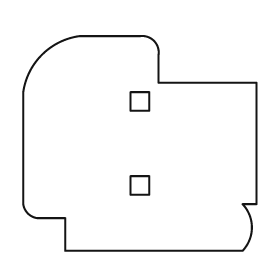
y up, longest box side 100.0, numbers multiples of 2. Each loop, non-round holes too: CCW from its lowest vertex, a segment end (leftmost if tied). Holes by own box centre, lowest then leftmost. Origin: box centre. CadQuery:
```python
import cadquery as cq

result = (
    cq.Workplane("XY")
    .moveTo(-32.0, -46.0)
    .lineTo(44.0, -46.0)
    .threePointArc((48.0, -36.0), (44.0, -26.0))
    .lineTo(50.0, -26.0)
    .lineTo(50.0, 26.0)
    .lineTo(8.0, 26.0)
    .lineTo(8.0, 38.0)
    .threePointArc((6.0, 44.0), (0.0, 46.0))
    .lineTo(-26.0, 46.0)
    .threePointArc((-42.0, 38.0), (-50.0, 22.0))
    .lineTo(-50.0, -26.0)
    .threePointArc((-48.0, -30.0), (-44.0, -32.0))
    .lineTo(-32.0, -32.0)
    .close()
    .moveTo(-4.0, -22.0)
    .lineTo(4.0, -22.0)
    .lineTo(4.0, -14.0)
    .lineTo(-4.0, -14.0)
    .close()
    .moveTo(-4.0, 14.0)
    .lineTo(4.0, 14.0)
    .lineTo(4.0, 22.0)
    .lineTo(-4.0, 22.0)
    .close()
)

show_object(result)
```